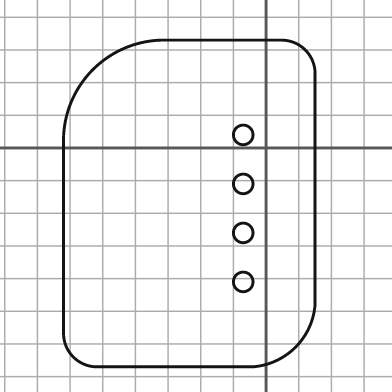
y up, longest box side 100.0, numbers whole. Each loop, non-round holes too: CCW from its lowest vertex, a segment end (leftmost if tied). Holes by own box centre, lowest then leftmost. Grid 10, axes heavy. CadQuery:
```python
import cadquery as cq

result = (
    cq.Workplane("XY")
    .moveTo(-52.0, -67.0)
    .lineTo(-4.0, -67.0)
    .threePointArc((9.0, -61.0), (15.0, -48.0))
    .lineTo(15.0, 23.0)
    .threePointArc((12.0, 30.0), (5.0, 33.0))
    .lineTo(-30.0, 33.0)
    .threePointArc((-53.0, 24.0), (-62.0, 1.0))
    .lineTo(-62.0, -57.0)
    .threePointArc((-59.0, -64.0), (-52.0, -67.0))
    .close()
    .moveTo(-7.0, -41.0)
    .circle(3.0)
    .moveTo(-7.0, -26.0)
    .circle(3.0)
    .moveTo(-7.0, -11.0)
    .circle(3.0)
    .moveTo(-7.0, 4.0)
    .circle(3.0)
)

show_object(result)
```